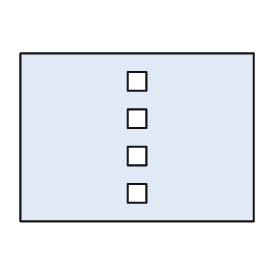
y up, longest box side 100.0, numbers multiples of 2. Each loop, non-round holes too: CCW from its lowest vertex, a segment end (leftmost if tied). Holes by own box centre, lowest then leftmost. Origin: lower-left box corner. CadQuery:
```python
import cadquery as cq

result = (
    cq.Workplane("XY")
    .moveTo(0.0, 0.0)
    .lineTo(100.0, 0.0)
    .lineTo(100.0, 72.0)
    .lineTo(0.0, 72.0)
    .close()
    .moveTo(46.0, 8.0)
    .lineTo(54.0, 8.0)
    .lineTo(54.0, 16.0)
    .lineTo(46.0, 16.0)
    .close()
    .moveTo(46.0, 24.0)
    .lineTo(54.0, 24.0)
    .lineTo(54.0, 32.0)
    .lineTo(46.0, 32.0)
    .close()
    .moveTo(46.0, 40.0)
    .lineTo(54.0, 40.0)
    .lineTo(54.0, 48.0)
    .lineTo(46.0, 48.0)
    .close()
    .moveTo(46.0, 56.0)
    .lineTo(54.0, 56.0)
    .lineTo(54.0, 64.0)
    .lineTo(46.0, 64.0)
    .close()
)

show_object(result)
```